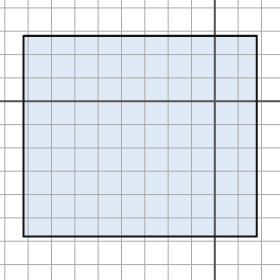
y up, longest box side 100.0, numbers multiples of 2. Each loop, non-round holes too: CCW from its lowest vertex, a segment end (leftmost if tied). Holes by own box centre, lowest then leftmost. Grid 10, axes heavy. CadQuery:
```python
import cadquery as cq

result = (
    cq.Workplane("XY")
    .moveTo(-82.0, -58.0)
    .lineTo(18.0, -58.0)
    .lineTo(18.0, 28.0)
    .lineTo(-82.0, 28.0)
    .close()
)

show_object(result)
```